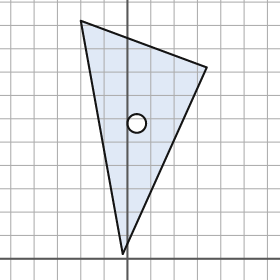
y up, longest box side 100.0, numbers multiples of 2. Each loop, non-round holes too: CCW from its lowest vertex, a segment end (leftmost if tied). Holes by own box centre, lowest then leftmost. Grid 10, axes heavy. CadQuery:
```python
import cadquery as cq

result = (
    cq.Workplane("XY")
    .moveTo(-2.0, 2.0)
    .lineTo(34.0, 82.0)
    .lineTo(-20.0, 102.0)
    .close()
    .moveTo(4.0, 58.0)
    .circle(4.0)
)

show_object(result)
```